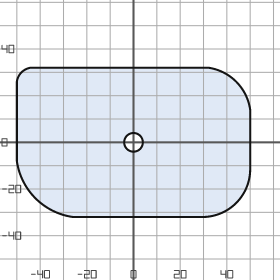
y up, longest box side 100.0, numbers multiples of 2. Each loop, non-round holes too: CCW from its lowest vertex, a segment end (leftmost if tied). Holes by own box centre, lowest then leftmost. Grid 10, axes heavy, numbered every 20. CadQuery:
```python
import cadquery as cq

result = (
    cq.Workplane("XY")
    .moveTo(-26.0, -32.0)
    .lineTo(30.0, -32.0)
    .threePointArc((44.0, -26.0), (50.0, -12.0))
    .lineTo(50.0, 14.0)
    .threePointArc((44.0, 26.0), (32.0, 32.0))
    .lineTo(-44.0, 32.0)
    .threePointArc((-48.0, 30.0), (-50.0, 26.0))
    .lineTo(-50.0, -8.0)
    .threePointArc((-42.0, -24.0), (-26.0, -32.0))
    .close()
    .moveTo(0.0, 0.0)
    .circle(4.0)
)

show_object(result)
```